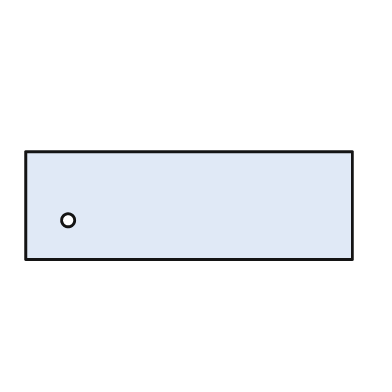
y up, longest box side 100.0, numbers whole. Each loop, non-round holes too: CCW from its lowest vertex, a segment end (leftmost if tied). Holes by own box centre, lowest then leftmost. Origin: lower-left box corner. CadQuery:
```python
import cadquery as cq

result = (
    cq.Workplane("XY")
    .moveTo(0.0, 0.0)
    .lineTo(100.0, 0.0)
    .lineTo(100.0, 33.0)
    .lineTo(0.0, 33.0)
    .close()
    .moveTo(13.0, 12.0)
    .circle(2.0)
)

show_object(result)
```